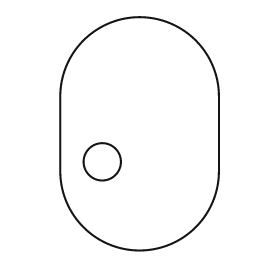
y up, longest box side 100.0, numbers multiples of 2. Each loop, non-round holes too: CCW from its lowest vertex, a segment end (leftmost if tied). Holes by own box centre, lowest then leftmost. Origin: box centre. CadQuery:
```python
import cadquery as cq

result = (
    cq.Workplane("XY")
    .moveTo(-34.0, -16.0)
    .threePointArc((0.0, -50.0), (34.0, -16.0))
    .lineTo(34.0, 16.0)
    .threePointArc((0.0, 50.0), (-34.0, 16.0))
    .close()
    .moveTo(-16.0, -12.0)
    .circle(8.0)
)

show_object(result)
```